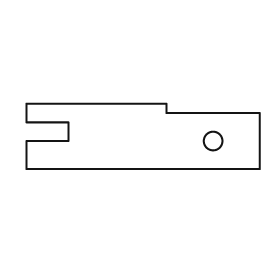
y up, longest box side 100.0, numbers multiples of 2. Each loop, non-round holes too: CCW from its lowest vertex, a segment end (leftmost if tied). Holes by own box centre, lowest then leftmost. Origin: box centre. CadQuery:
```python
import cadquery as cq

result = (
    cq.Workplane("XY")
    .moveTo(-50.0, -14.0)
    .lineTo(50.0, -14.0)
    .lineTo(50.0, 10.0)
    .lineTo(10.0, 10.0)
    .lineTo(10.0, 14.0)
    .lineTo(-50.0, 14.0)
    .lineTo(-50.0, 6.0)
    .lineTo(-32.0, 6.0)
    .lineTo(-32.0, -2.0)
    .lineTo(-50.0, -2.0)
    .close()
    .moveTo(30.0, -2.0)
    .circle(4.0)
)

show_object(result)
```